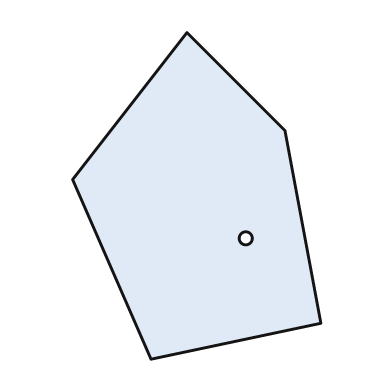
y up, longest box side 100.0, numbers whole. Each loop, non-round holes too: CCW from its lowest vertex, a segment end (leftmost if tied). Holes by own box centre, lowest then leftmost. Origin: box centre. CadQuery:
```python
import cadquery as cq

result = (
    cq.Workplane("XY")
    .moveTo(-14.0, -50.0)
    .lineTo(38.0, -39.0)
    .lineTo(27.0, 20.0)
    .lineTo(-3.0, 50.0)
    .lineTo(-38.0, 5.0)
    .close()
    .moveTo(15.0, -13.0)
    .circle(2.0)
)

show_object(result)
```